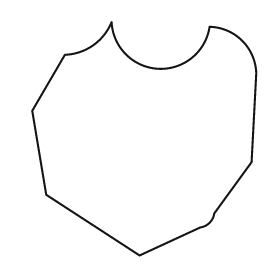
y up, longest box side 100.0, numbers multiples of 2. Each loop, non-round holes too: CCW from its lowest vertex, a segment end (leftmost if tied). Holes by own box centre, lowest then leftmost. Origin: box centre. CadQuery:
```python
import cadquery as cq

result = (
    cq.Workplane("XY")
    .moveTo(-2.0, -50.0)
    .lineTo(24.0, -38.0)
    .threePointArc((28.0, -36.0), (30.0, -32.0))
    .lineTo(46.0, -10.0)
    .lineTo(48.0, 28.0)
    .threePointArc((42.0, 42.0), (28.0, 48.0))
    .threePointArc((6.0, 30.0), (-14.0, 50.0))
    .threePointArc((-22.0, 40.0), (-34.0, 36.0))
    .lineTo(-48.0, 12.0)
    .lineTo(-42.0, -24.0)
    .close()
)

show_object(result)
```